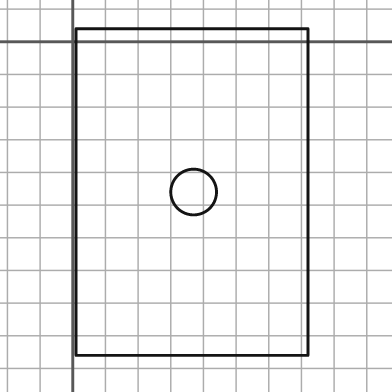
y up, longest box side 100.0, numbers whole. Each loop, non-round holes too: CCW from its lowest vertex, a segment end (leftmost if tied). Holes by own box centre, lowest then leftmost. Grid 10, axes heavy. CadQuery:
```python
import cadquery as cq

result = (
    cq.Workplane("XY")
    .moveTo(1.0, -96.0)
    .lineTo(72.0, -96.0)
    .lineTo(72.0, 4.0)
    .lineTo(1.0, 4.0)
    .close()
    .moveTo(37.0, -46.0)
    .circle(7.0)
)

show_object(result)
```